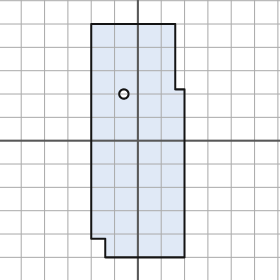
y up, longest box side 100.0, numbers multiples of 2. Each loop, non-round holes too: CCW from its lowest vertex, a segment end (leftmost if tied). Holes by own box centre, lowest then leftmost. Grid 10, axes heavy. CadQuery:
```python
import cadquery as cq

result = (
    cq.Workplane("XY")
    .moveTo(-14.0, -50.0)
    .lineTo(20.0, -50.0)
    .lineTo(20.0, 22.0)
    .lineTo(16.0, 22.0)
    .lineTo(16.0, 50.0)
    .lineTo(-20.0, 50.0)
    .lineTo(-20.0, -42.0)
    .lineTo(-14.0, -42.0)
    .close()
    .moveTo(-6.0, 20.0)
    .circle(2.0)
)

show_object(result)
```